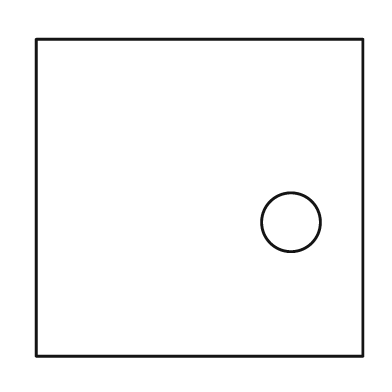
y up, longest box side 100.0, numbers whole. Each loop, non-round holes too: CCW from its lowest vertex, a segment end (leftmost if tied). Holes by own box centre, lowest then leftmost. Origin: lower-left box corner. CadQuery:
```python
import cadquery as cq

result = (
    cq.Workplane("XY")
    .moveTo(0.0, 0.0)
    .lineTo(100.0, 0.0)
    .lineTo(100.0, 97.0)
    .lineTo(0.0, 97.0)
    .close()
    .moveTo(78.0, 41.0)
    .circle(9.0)
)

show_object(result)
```